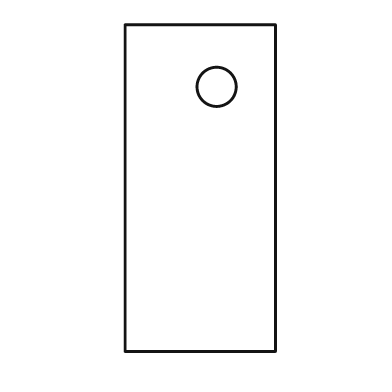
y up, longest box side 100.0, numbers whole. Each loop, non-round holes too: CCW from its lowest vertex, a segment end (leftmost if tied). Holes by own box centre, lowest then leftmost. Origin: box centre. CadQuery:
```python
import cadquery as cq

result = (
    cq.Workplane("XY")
    .moveTo(-23.0, -50.0)
    .lineTo(23.0, -50.0)
    .lineTo(23.0, 50.0)
    .lineTo(-23.0, 50.0)
    .close()
    .moveTo(5.0, 31.0)
    .circle(6.0)
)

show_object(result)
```